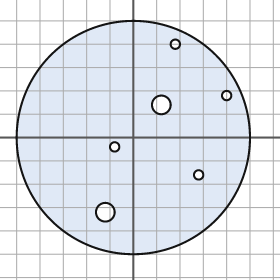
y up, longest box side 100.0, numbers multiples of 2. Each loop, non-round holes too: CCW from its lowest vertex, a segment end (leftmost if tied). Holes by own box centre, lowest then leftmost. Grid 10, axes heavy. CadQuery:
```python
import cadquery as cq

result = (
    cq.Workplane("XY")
    .moveTo(0.0, 0.0)
    .circle(50.0)
    .moveTo(-12.0, -32.0)
    .circle(4.0)
    .moveTo(28.0, -16.0)
    .circle(2.0)
    .moveTo(-8.0, -4.0)
    .circle(2.0)
    .moveTo(12.0, 14.0)
    .circle(4.0)
    .moveTo(40.0, 18.0)
    .circle(2.0)
    .moveTo(18.0, 40.0)
    .circle(2.0)
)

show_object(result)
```